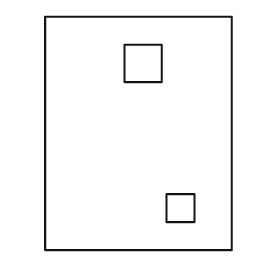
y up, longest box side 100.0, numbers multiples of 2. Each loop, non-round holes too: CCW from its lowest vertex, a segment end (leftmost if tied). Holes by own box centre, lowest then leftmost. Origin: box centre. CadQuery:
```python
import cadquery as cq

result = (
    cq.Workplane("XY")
    .moveTo(-40.0, -50.0)
    .lineTo(40.0, -50.0)
    .lineTo(40.0, 50.0)
    .lineTo(-40.0, 50.0)
    .close()
    .moveTo(12.0, -38.0)
    .lineTo(24.0, -38.0)
    .lineTo(24.0, -26.0)
    .lineTo(12.0, -26.0)
    .close()
    .moveTo(-6.0, 22.0)
    .lineTo(10.0, 22.0)
    .lineTo(10.0, 38.0)
    .lineTo(-6.0, 38.0)
    .close()
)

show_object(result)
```